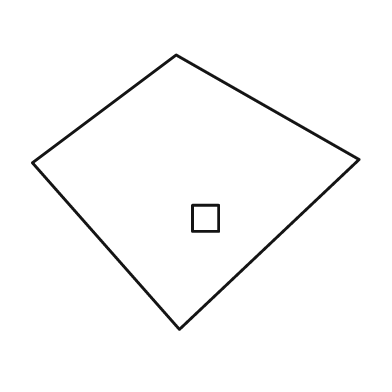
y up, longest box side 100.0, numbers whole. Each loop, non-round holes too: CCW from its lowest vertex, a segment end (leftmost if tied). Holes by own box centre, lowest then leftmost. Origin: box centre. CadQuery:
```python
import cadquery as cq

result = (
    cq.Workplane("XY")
    .moveTo(-5.0, -42.0)
    .lineTo(50.0, 10.0)
    .lineTo(-6.0, 42.0)
    .lineTo(-50.0, 9.0)
    .close()
    .moveTo(-1.0, -12.0)
    .lineTo(7.0, -12.0)
    .lineTo(7.0, -4.0)
    .lineTo(-1.0, -4.0)
    .close()
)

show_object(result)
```